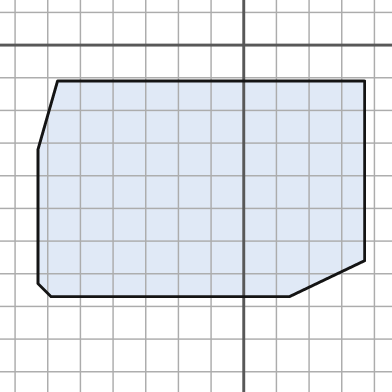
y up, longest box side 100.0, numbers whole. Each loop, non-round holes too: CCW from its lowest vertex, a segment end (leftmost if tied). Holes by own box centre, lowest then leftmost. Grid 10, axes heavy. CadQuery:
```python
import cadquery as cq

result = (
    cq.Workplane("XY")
    .moveTo(-59.0, -77.0)
    .lineTo(14.0, -77.0)
    .lineTo(37.0, -66.0)
    .lineTo(37.0, -11.0)
    .lineTo(-57.0, -11.0)
    .lineTo(-63.0, -32.0)
    .lineTo(-63.0, -73.0)
    .close()
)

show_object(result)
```